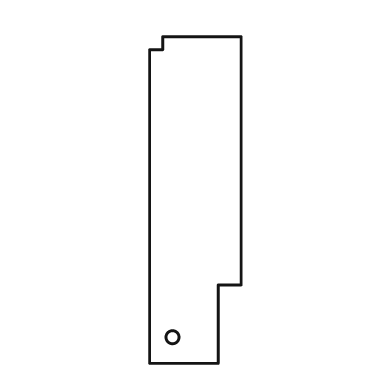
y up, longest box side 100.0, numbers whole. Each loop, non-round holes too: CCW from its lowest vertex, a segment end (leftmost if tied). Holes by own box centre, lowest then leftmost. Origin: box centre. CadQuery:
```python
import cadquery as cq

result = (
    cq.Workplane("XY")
    .moveTo(-14.0, -50.0)
    .lineTo(7.0, -50.0)
    .lineTo(7.0, -26.0)
    .lineTo(14.0, -26.0)
    .lineTo(14.0, 50.0)
    .lineTo(-10.0, 50.0)
    .lineTo(-10.0, 46.0)
    .lineTo(-14.0, 46.0)
    .close()
    .moveTo(-7.0, -42.0)
    .circle(2.0)
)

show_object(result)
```